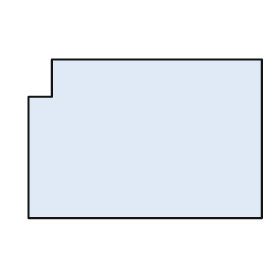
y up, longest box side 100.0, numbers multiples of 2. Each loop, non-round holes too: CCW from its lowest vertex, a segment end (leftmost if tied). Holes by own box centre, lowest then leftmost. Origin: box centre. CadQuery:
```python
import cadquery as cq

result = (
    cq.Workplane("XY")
    .moveTo(-50.0, -34.0)
    .lineTo(50.0, -34.0)
    .lineTo(50.0, 34.0)
    .lineTo(-40.0, 34.0)
    .lineTo(-40.0, 18.0)
    .lineTo(-50.0, 18.0)
    .close()
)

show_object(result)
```